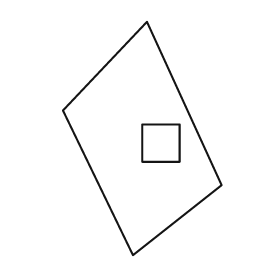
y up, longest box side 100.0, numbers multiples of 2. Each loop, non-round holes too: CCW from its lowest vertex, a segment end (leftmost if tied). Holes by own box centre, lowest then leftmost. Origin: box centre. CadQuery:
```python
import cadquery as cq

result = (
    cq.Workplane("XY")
    .moveTo(-4.0, -50.0)
    .lineTo(34.0, -20.0)
    .lineTo(2.0, 50.0)
    .lineTo(-34.0, 12.0)
    .close()
    .moveTo(0.0, -10.0)
    .lineTo(16.0, -10.0)
    .lineTo(16.0, 6.0)
    .lineTo(0.0, 6.0)
    .close()
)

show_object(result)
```